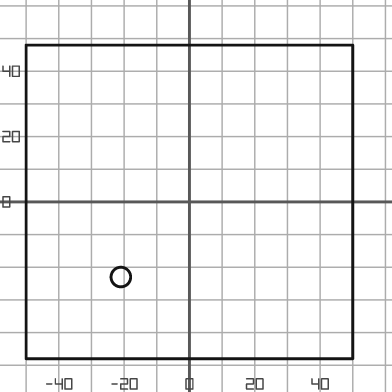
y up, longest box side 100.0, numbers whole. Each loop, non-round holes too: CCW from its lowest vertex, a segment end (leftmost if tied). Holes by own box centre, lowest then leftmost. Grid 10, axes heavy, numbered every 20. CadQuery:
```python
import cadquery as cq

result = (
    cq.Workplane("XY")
    .moveTo(-50.0, -48.0)
    .lineTo(50.0, -48.0)
    .lineTo(50.0, 48.0)
    .lineTo(-50.0, 48.0)
    .close()
    .moveTo(-21.0, -23.0)
    .circle(3.0)
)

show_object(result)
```